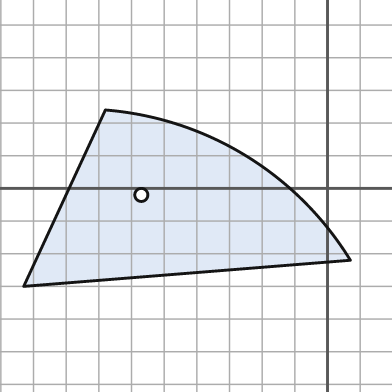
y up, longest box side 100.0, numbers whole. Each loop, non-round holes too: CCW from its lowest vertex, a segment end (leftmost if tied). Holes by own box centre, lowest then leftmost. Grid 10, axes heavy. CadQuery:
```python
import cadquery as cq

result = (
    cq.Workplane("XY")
    .moveTo(-93.0, -30.0)
    .lineTo(7.0, -22.0)
    .threePointArc((-25.0, 10.0), (-68.0, 24.0))
    .close()
    .moveTo(-57.0, -2.0)
    .circle(2.0)
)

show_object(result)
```